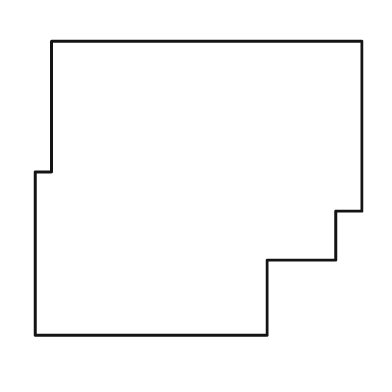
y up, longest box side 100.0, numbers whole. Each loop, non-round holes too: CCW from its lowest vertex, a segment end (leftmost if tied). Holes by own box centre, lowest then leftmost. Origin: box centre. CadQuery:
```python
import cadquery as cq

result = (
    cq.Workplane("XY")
    .moveTo(-50.0, -45.0)
    .lineTo(21.0, -45.0)
    .lineTo(21.0, -22.0)
    .lineTo(42.0, -22.0)
    .lineTo(42.0, -7.0)
    .lineTo(50.0, -7.0)
    .lineTo(50.0, 45.0)
    .lineTo(-45.0, 45.0)
    .lineTo(-45.0, 5.0)
    .lineTo(-50.0, 5.0)
    .close()
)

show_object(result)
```